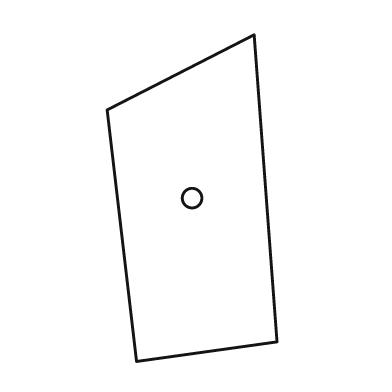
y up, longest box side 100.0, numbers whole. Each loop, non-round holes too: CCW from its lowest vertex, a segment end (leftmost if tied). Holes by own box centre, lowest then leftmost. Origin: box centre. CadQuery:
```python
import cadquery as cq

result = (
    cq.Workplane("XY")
    .moveTo(-17.0, -50.0)
    .lineTo(26.0, -44.0)
    .lineTo(19.0, 50.0)
    .lineTo(-26.0, 27.0)
    .close()
    .moveTo(0.0, 0.0)
    .circle(3.0)
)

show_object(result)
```